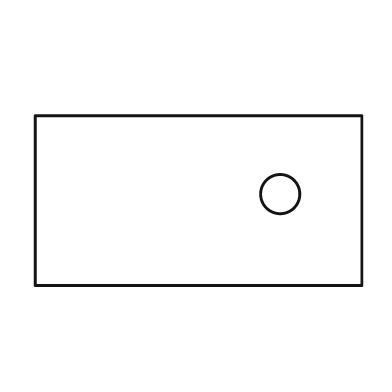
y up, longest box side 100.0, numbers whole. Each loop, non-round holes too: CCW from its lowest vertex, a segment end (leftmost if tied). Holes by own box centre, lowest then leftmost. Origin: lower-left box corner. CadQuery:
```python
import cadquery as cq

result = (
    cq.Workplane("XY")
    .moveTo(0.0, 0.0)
    .lineTo(100.0, 0.0)
    .lineTo(100.0, 52.0)
    .lineTo(0.0, 52.0)
    .close()
    .moveTo(75.0, 28.0)
    .circle(6.0)
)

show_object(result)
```